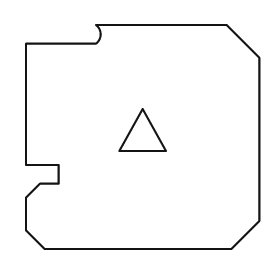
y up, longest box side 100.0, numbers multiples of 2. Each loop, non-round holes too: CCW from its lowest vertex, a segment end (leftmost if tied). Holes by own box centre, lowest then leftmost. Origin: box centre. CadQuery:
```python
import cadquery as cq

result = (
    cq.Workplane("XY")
    .moveTo(-42.0, -48.0)
    .lineTo(38.0, -48.0)
    .lineTo(50.0, -36.0)
    .lineTo(50.0, 34.0)
    .lineTo(36.0, 48.0)
    .lineTo(-20.0, 48.0)
    .threePointArc((-18.0, 44.0), (-20.0, 40.0))
    .lineTo(-50.0, 40.0)
    .lineTo(-50.0, -12.0)
    .lineTo(-36.0, -12.0)
    .lineTo(-36.0, -20.0)
    .lineTo(-44.0, -20.0)
    .lineTo(-50.0, -26.0)
    .lineTo(-50.0, -40.0)
    .close()
    .moveTo(-10.0, -6.0)
    .lineTo(10.0, -6.0)
    .lineTo(0.0, 12.0)
    .close()
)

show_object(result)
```